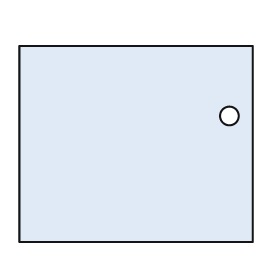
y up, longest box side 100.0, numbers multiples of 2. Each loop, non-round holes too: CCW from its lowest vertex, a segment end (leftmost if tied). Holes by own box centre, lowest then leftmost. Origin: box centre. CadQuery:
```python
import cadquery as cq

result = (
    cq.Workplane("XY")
    .moveTo(-50.0, -42.0)
    .lineTo(50.0, -42.0)
    .lineTo(50.0, 42.0)
    .lineTo(-50.0, 42.0)
    .close()
    .moveTo(40.0, 12.0)
    .circle(4.0)
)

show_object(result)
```